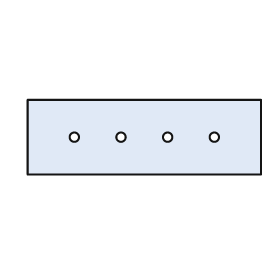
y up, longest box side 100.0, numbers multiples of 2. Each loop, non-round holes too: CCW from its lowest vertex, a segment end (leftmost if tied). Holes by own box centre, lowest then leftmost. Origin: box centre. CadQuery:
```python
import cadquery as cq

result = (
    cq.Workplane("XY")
    .moveTo(-50.0, -16.0)
    .lineTo(50.0, -16.0)
    .lineTo(50.0, 16.0)
    .lineTo(-50.0, 16.0)
    .close()
    .moveTo(-30.0, 0.0)
    .circle(2.0)
    .moveTo(-10.0, 0.0)
    .circle(2.0)
    .moveTo(10.0, 0.0)
    .circle(2.0)
    .moveTo(30.0, 0.0)
    .circle(2.0)
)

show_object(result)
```